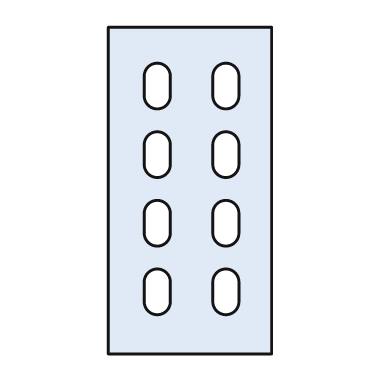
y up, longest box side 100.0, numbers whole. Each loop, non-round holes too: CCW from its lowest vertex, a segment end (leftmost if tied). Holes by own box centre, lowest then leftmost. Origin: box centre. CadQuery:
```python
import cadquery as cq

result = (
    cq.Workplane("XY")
    .moveTo(-25.0, -50.0)
    .lineTo(25.0, -50.0)
    .lineTo(25.0, 50.0)
    .lineTo(-25.0, 50.0)
    .close()
    .moveTo(-14.0, -34.0)
    .threePointArc((-10.0, -38.0), (-6.0, -34.0))
    .lineTo(-6.0, -28.0)
    .threePointArc((-10.0, -24.0), (-14.0, -28.0))
    .close()
    .moveTo(7.0, -34.0)
    .threePointArc((11.0, -38.0), (15.0, -34.0))
    .lineTo(15.0, -28.0)
    .threePointArc((11.0, -24.0), (7.0, -28.0))
    .close()
    .moveTo(-14.0, -13.0)
    .threePointArc((-10.0, -17.0), (-6.0, -13.0))
    .lineTo(-6.0, -7.0)
    .threePointArc((-10.0, -3.0), (-14.0, -7.0))
    .close()
    .moveTo(7.0, -13.0)
    .threePointArc((11.0, -17.0), (15.0, -13.0))
    .lineTo(15.0, -7.0)
    .threePointArc((11.0, -3.0), (7.0, -7.0))
    .close()
    .moveTo(-14.0, 8.0)
    .threePointArc((-10.0, 4.0), (-6.0, 8.0))
    .lineTo(-6.0, 14.0)
    .threePointArc((-10.0, 18.0), (-14.0, 14.0))
    .close()
    .moveTo(7.0, 8.0)
    .threePointArc((11.0, 4.0), (15.0, 8.0))
    .lineTo(15.0, 14.0)
    .threePointArc((11.0, 18.0), (7.0, 14.0))
    .close()
    .moveTo(-14.0, 29.0)
    .threePointArc((-10.0, 25.0), (-6.0, 29.0))
    .lineTo(-6.0, 35.0)
    .threePointArc((-10.0, 39.0), (-14.0, 35.0))
    .close()
    .moveTo(7.0, 29.0)
    .threePointArc((11.0, 25.0), (15.0, 29.0))
    .lineTo(15.0, 35.0)
    .threePointArc((11.0, 39.0), (7.0, 35.0))
    .close()
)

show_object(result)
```